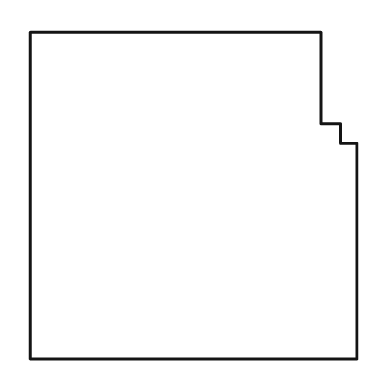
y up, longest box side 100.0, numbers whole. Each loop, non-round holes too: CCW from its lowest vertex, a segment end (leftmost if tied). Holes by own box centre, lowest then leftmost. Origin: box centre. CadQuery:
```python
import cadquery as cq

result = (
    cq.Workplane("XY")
    .moveTo(-50.0, -50.0)
    .lineTo(50.0, -50.0)
    .lineTo(50.0, 16.0)
    .lineTo(45.0, 16.0)
    .lineTo(45.0, 22.0)
    .lineTo(39.0, 22.0)
    .lineTo(39.0, 50.0)
    .lineTo(-50.0, 50.0)
    .close()
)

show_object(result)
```